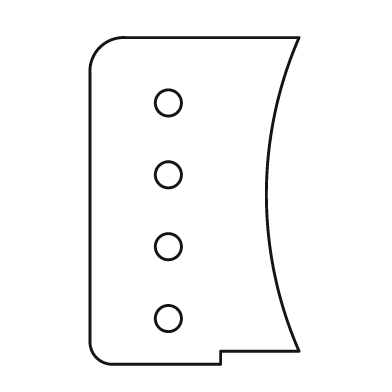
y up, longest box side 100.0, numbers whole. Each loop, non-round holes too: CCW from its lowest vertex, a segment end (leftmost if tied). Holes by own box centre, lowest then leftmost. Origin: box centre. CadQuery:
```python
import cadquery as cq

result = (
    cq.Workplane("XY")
    .moveTo(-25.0, -50.0)
    .lineTo(8.0, -50.0)
    .lineTo(8.0, -46.0)
    .lineTo(32.0, -46.0)
    .threePointArc((22.0, 2.0), (32.0, 50.0))
    .lineTo(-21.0, 50.0)
    .threePointArc((-29.0, 47.0), (-32.0, 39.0))
    .lineTo(-32.0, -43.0)
    .threePointArc((-30.0, -48.0), (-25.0, -50.0))
    .close()
    .moveTo(-8.0, -36.0)
    .circle(4.0)
    .moveTo(-8.0, -14.0)
    .circle(4.0)
    .moveTo(-8.0, 8.0)
    .circle(4.0)
    .moveTo(-8.0, 30.0)
    .circle(4.0)
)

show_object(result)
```